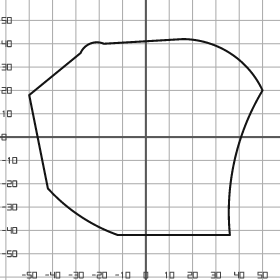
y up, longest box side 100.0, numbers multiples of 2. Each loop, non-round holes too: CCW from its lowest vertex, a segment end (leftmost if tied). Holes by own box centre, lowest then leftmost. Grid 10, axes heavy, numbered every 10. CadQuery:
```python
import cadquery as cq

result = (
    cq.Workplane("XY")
    .moveTo(-12.0, -42.0)
    .lineTo(36.0, -42.0)
    .threePointArc((38.0, -10.0), (50.0, 20.0))
    .threePointArc((36.0, 36.0), (16.0, 42.0))
    .lineTo(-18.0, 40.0)
    .threePointArc((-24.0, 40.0), (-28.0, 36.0))
    .lineTo(-50.0, 18.0)
    .lineTo(-42.0, -22.0)
    .threePointArc((-28.0, -34.0), (-12.0, -42.0))
    .close()
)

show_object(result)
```